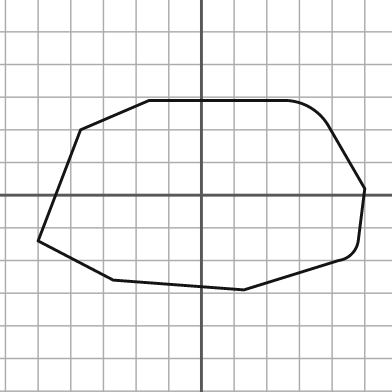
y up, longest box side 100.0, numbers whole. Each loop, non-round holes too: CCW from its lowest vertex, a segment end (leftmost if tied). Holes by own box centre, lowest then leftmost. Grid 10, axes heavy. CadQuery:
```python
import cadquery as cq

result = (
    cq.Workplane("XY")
    .moveTo(13.0, -29.0)
    .lineTo(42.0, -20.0)
    .threePointArc((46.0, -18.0), (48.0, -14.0))
    .lineTo(50.0, 2.0)
    .lineTo(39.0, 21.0)
    .threePointArc((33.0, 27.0), (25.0, 29.0))
    .lineTo(-16.0, 29.0)
    .lineTo(-37.0, 20.0)
    .lineTo(-50.0, -14.0)
    .lineTo(-27.0, -26.0)
    .close()
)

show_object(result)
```